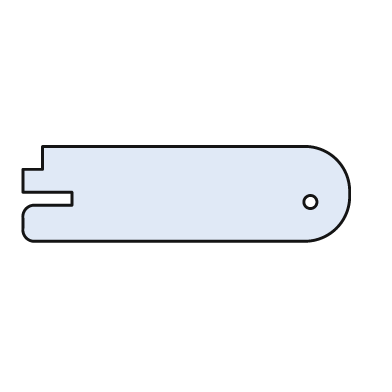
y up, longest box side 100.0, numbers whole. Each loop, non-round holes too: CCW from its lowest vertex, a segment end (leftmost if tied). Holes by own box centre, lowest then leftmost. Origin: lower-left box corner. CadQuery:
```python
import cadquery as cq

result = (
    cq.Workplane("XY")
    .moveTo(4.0, 0.0)
    .lineTo(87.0, 0.0)
    .threePointArc((96.0, 4.0), (100.0, 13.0))
    .lineTo(100.0, 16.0)
    .threePointArc((96.0, 25.0), (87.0, 29.0))
    .lineTo(6.0, 29.0)
    .lineTo(6.0, 22.0)
    .lineTo(0.0, 22.0)
    .lineTo(0.0, 15.0)
    .lineTo(15.0, 15.0)
    .lineTo(15.0, 11.0)
    .lineTo(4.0, 11.0)
    .threePointArc((1.0, 10.0), (0.0, 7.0))
    .lineTo(0.0, 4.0)
    .threePointArc((1.0, 1.0), (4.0, 0.0))
    .close()
    .moveTo(88.0, 12.0)
    .circle(2.0)
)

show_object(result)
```